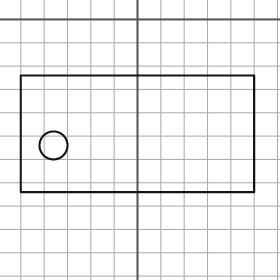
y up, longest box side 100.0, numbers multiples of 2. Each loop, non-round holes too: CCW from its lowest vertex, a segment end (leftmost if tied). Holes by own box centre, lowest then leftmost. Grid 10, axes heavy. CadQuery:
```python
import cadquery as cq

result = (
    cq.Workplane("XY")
    .moveTo(-50.0, -74.0)
    .lineTo(50.0, -74.0)
    .lineTo(50.0, -24.0)
    .lineTo(-50.0, -24.0)
    .close()
    .moveTo(-36.0, -54.0)
    .circle(6.0)
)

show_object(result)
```